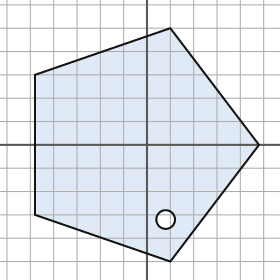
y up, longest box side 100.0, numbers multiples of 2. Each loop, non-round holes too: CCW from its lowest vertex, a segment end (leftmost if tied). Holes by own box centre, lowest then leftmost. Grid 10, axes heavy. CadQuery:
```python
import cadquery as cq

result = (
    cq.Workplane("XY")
    .moveTo(10.0, -50.0)
    .lineTo(48.0, 0.0)
    .lineTo(10.0, 50.0)
    .lineTo(-48.0, 30.0)
    .lineTo(-48.0, -30.0)
    .close()
    .moveTo(8.0, -32.0)
    .circle(4.0)
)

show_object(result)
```